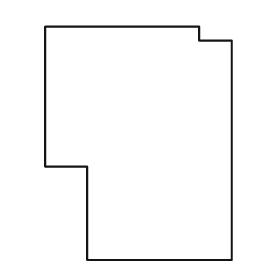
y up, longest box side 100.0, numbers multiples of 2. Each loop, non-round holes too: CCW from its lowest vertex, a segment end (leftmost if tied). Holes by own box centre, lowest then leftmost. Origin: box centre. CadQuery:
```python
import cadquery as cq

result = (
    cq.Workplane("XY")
    .moveTo(-22.0, -50.0)
    .lineTo(40.0, -50.0)
    .lineTo(40.0, 44.0)
    .lineTo(26.0, 44.0)
    .lineTo(26.0, 50.0)
    .lineTo(-40.0, 50.0)
    .lineTo(-40.0, -10.0)
    .lineTo(-22.0, -10.0)
    .close()
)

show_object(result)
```